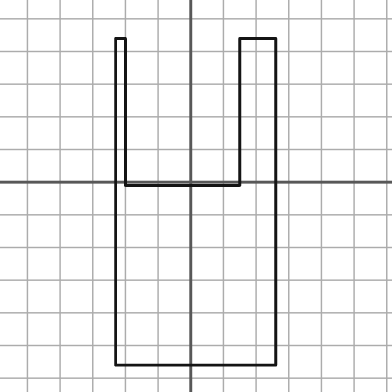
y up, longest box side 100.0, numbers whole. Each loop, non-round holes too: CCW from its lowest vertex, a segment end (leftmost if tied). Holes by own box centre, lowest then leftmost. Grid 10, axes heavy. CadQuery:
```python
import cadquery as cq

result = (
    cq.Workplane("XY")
    .moveTo(-23.0, -56.0)
    .lineTo(26.0, -56.0)
    .lineTo(26.0, 44.0)
    .lineTo(15.0, 44.0)
    .lineTo(15.0, -1.0)
    .lineTo(-20.0, -1.0)
    .lineTo(-20.0, 44.0)
    .lineTo(-23.0, 44.0)
    .close()
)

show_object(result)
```